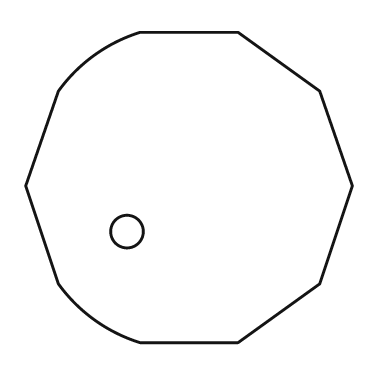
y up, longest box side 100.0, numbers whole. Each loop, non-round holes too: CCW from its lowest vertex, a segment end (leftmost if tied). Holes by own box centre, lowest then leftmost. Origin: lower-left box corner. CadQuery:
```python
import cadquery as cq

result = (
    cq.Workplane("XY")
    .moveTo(35.0, 0.0)
    .lineTo(65.0, 0.0)
    .lineTo(90.0, 18.0)
    .lineTo(100.0, 48.0)
    .lineTo(90.0, 77.0)
    .lineTo(65.0, 95.0)
    .lineTo(35.0, 95.0)
    .threePointArc((21.0, 88.0), (10.0, 77.0))
    .lineTo(0.0, 48.0)
    .lineTo(10.0, 18.0)
    .threePointArc((21.0, 7.0), (35.0, 0.0))
    .close()
    .moveTo(31.0, 34.0)
    .circle(5.0)
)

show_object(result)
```